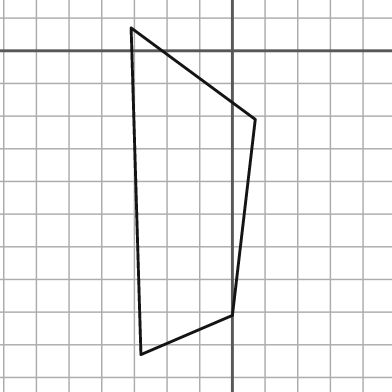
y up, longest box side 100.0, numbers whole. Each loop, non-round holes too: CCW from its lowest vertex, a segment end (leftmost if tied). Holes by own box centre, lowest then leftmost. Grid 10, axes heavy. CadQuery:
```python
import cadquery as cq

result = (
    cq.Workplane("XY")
    .moveTo(-28.0, -93.0)
    .lineTo(0.0, -81.0)
    .lineTo(7.0, -21.0)
    .lineTo(-31.0, 7.0)
    .close()
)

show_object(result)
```